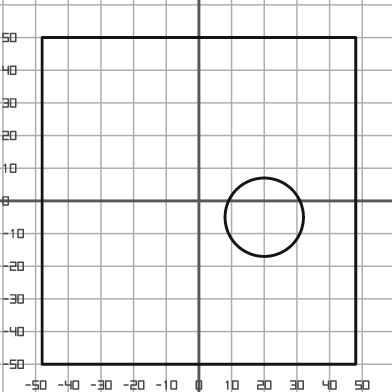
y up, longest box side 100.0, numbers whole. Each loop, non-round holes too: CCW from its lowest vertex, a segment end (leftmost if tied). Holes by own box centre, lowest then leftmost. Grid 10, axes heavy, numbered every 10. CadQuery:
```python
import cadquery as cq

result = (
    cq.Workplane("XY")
    .moveTo(-48.0, -50.0)
    .lineTo(48.0, -50.0)
    .lineTo(48.0, 50.0)
    .lineTo(-48.0, 50.0)
    .close()
    .moveTo(20.0, -5.0)
    .circle(12.0)
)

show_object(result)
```